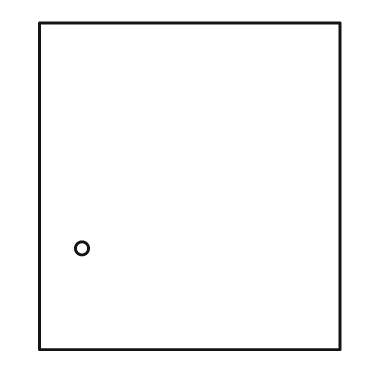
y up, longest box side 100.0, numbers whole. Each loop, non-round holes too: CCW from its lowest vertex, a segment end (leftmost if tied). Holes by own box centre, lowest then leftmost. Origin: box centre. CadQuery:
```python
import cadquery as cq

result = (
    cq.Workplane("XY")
    .moveTo(-46.0, -50.0)
    .lineTo(46.0, -50.0)
    .lineTo(46.0, 50.0)
    .lineTo(-46.0, 50.0)
    .close()
    .moveTo(-33.0, -19.0)
    .circle(2.0)
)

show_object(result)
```